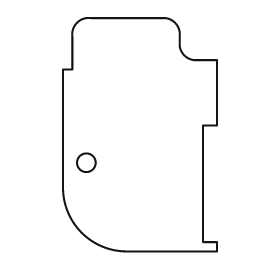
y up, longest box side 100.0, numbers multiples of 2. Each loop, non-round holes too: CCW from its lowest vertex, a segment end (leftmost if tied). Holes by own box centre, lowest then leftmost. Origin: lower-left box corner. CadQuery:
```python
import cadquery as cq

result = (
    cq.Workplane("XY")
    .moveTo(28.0, 0.0)
    .lineTo(66.0, 0.0)
    .lineTo(66.0, 4.0)
    .lineTo(60.0, 4.0)
    .lineTo(60.0, 54.0)
    .lineTo(66.0, 54.0)
    .lineTo(66.0, 82.0)
    .lineTo(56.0, 82.0)
    .threePointArc((52.0, 84.0), (50.0, 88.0))
    .lineTo(50.0, 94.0)
    .threePointArc((48.0, 98.0), (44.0, 100.0))
    .lineTo(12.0, 100.0)
    .threePointArc((6.0, 98.0), (4.0, 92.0))
    .lineTo(4.0, 78.0)
    .lineTo(0.0, 78.0)
    .lineTo(0.0, 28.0)
    .threePointArc((8.0, 8.0), (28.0, 0.0))
    .close()
    .moveTo(10.0, 38.0)
    .circle(4.0)
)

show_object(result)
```